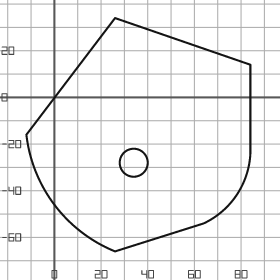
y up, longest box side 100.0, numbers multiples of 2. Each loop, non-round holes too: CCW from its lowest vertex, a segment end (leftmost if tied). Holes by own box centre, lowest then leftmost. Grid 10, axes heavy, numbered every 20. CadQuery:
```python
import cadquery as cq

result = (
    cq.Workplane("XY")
    .moveTo(26.0, -66.0)
    .lineTo(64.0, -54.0)
    .threePointArc((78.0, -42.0), (84.0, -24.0))
    .lineTo(84.0, 14.0)
    .lineTo(26.0, 34.0)
    .lineTo(-12.0, -16.0)
    .threePointArc((0.0, -46.0), (26.0, -66.0))
    .close()
    .moveTo(34.0, -28.0)
    .circle(6.0)
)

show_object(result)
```